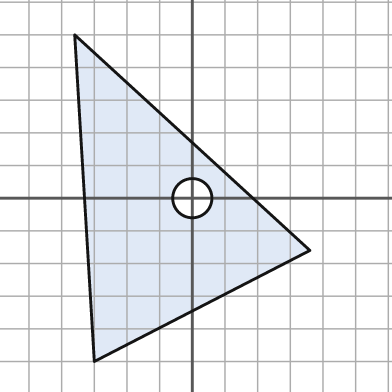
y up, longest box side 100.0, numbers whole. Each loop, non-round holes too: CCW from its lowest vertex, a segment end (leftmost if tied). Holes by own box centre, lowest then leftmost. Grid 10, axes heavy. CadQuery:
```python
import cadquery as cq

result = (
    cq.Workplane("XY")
    .moveTo(-30.0, -50.0)
    .lineTo(36.0, -16.0)
    .lineTo(-36.0, 50.0)
    .close()
    .moveTo(0.0, 0.0)
    .circle(6.0)
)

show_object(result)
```